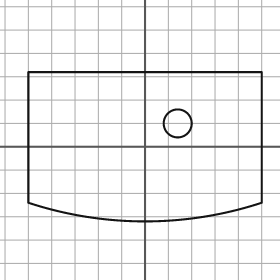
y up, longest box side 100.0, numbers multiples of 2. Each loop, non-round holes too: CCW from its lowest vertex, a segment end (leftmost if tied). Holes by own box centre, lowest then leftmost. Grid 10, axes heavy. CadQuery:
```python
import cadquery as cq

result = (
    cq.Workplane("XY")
    .moveTo(-50.0, -24.0)
    .threePointArc((0.0, -32.0), (50.0, -24.0))
    .lineTo(50.0, 32.0)
    .lineTo(-50.0, 32.0)
    .close()
    .moveTo(14.0, 10.0)
    .circle(6.0)
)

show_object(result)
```